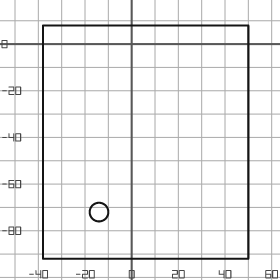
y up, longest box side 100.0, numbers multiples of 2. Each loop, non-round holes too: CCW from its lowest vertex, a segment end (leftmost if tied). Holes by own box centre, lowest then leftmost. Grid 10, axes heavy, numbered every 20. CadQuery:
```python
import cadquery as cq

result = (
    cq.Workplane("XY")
    .moveTo(-38.0, -92.0)
    .lineTo(50.0, -92.0)
    .lineTo(50.0, 8.0)
    .lineTo(-38.0, 8.0)
    .close()
    .moveTo(-14.0, -72.0)
    .circle(4.0)
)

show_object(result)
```